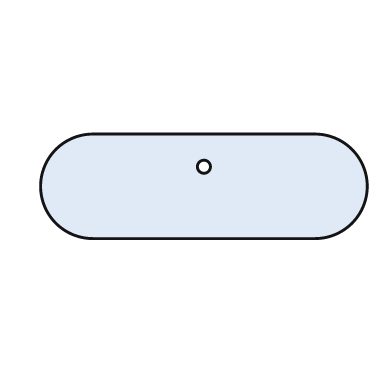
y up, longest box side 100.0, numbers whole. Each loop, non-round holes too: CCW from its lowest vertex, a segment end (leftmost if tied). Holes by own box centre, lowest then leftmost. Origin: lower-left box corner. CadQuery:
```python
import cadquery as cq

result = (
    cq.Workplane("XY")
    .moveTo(16.0, 0.0)
    .lineTo(84.0, 0.0)
    .threePointArc((100.0, 16.0), (84.0, 32.0))
    .lineTo(16.0, 32.0)
    .threePointArc((0.0, 16.0), (16.0, 0.0))
    .close()
    .moveTo(50.0, 22.0)
    .circle(2.0)
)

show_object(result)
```